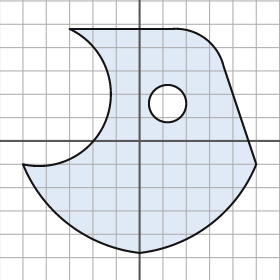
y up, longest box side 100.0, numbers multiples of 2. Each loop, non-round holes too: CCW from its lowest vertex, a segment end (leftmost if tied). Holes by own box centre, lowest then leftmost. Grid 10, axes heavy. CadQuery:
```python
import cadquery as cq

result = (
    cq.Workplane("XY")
    .moveTo(0.0, -48.0)
    .threePointArc((30.0, -36.0), (50.0, -10.0))
    .lineTo(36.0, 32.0)
    .threePointArc((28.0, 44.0), (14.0, 48.0))
    .lineTo(-30.0, 48.0)
    .threePointArc((-14.0, 10.0), (-50.0, -10.0))
    .threePointArc((-30.0, -36.0), (0.0, -48.0))
    .close()
    .moveTo(12.0, 16.0)
    .circle(8.0)
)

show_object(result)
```